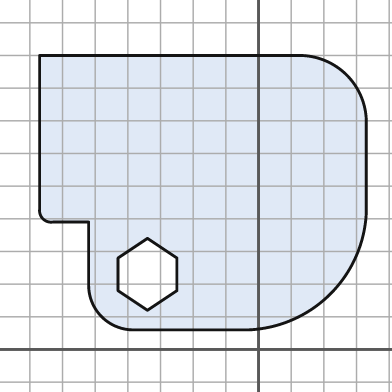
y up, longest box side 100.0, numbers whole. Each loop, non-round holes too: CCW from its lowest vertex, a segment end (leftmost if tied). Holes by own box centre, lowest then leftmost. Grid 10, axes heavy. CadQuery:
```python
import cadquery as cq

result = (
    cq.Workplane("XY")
    .moveTo(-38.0, 6.0)
    .lineTo(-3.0, 6.0)
    .threePointArc((22.0, 17.0), (33.0, 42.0))
    .lineTo(33.0, 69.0)
    .threePointArc((27.0, 84.0), (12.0, 90.0))
    .lineTo(-67.0, 90.0)
    .lineTo(-67.0, 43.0)
    .threePointArc((-66.0, 40.0), (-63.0, 39.0))
    .lineTo(-52.0, 39.0)
    .lineTo(-52.0, 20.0)
    .threePointArc((-48.0, 10.0), (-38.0, 6.0))
    .close()
    .moveTo(-34.0, 12.0)
    .lineTo(-25.0, 18.0)
    .lineTo(-25.0, 28.0)
    .lineTo(-34.0, 34.0)
    .lineTo(-43.0, 28.0)
    .lineTo(-43.0, 18.0)
    .close()
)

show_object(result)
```